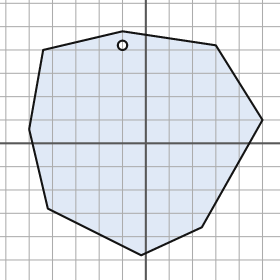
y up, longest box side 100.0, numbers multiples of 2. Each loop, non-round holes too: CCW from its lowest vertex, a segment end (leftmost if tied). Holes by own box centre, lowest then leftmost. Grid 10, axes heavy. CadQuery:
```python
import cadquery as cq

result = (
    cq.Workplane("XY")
    .moveTo(-2.0, -48.0)
    .lineTo(24.0, -36.0)
    .lineTo(50.0, 10.0)
    .lineTo(30.0, 42.0)
    .lineTo(-10.0, 48.0)
    .lineTo(-44.0, 40.0)
    .lineTo(-50.0, 6.0)
    .lineTo(-42.0, -28.0)
    .close()
    .moveTo(-10.0, 42.0)
    .circle(2.0)
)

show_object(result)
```